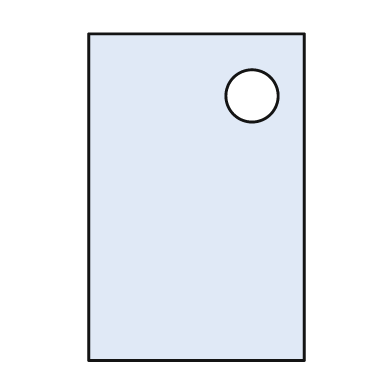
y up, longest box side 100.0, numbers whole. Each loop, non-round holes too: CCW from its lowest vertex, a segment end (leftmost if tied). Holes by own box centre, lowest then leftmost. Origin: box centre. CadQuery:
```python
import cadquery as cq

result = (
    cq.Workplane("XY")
    .moveTo(-33.0, -50.0)
    .lineTo(33.0, -50.0)
    .lineTo(33.0, 50.0)
    .lineTo(-33.0, 50.0)
    .close()
    .moveTo(17.0, 31.0)
    .circle(8.0)
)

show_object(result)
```